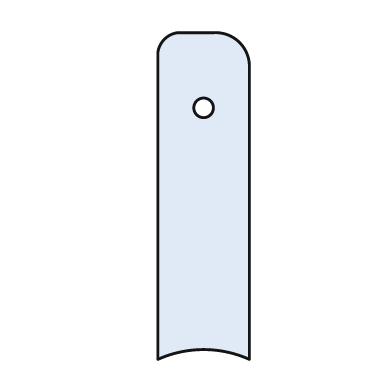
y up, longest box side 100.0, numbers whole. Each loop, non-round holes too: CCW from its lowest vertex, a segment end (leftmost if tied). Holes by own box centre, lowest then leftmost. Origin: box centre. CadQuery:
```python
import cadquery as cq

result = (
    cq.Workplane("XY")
    .moveTo(-14.0, -50.0)
    .threePointArc((0.0, -47.0), (14.0, -50.0))
    .lineTo(14.0, 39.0)
    .threePointArc((11.0, 47.0), (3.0, 50.0))
    .lineTo(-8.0, 50.0)
    .threePointArc((-12.0, 48.0), (-14.0, 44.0))
    .close()
    .moveTo(0.0, 27.0)
    .circle(3.0)
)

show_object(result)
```